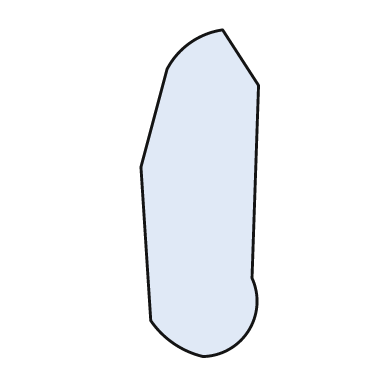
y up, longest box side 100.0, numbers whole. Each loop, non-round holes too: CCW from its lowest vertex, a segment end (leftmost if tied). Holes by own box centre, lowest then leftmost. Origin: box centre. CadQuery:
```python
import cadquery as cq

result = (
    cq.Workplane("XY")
    .moveTo(1.0, -50.0)
    .threePointArc((15.0, -42.0), (16.0, -26.0))
    .lineTo(18.0, 33.0)
    .lineTo(7.0, 50.0)
    .threePointArc((-3.0, 46.0), (-10.0, 38.0))
    .lineTo(-18.0, 8.0)
    .lineTo(-15.0, -39.0)
    .threePointArc((-8.0, -46.0), (1.0, -50.0))
    .close()
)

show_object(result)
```